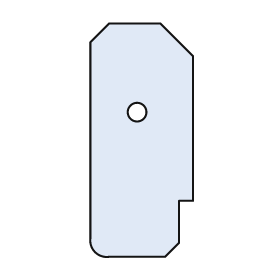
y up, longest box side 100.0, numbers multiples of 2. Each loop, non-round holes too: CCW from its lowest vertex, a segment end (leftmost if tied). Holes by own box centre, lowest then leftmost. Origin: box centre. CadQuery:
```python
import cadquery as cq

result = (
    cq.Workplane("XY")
    .moveTo(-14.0, -50.0)
    .lineTo(10.0, -50.0)
    .lineTo(16.0, -44.0)
    .lineTo(16.0, -26.0)
    .lineTo(22.0, -26.0)
    .lineTo(22.0, 36.0)
    .lineTo(8.0, 50.0)
    .lineTo(-14.0, 50.0)
    .lineTo(-22.0, 42.0)
    .lineTo(-22.0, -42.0)
    .threePointArc((-20.0, -48.0), (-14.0, -50.0))
    .close()
    .moveTo(-2.0, 12.0)
    .circle(4.0)
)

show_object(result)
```